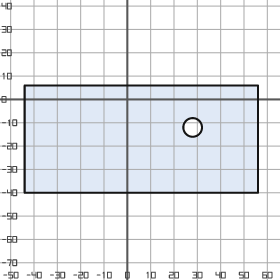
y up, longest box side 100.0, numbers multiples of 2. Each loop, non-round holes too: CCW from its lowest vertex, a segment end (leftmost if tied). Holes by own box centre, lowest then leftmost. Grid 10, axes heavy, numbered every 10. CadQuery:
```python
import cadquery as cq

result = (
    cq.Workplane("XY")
    .moveTo(-44.0, -40.0)
    .lineTo(56.0, -40.0)
    .lineTo(56.0, 6.0)
    .lineTo(-44.0, 6.0)
    .close()
    .moveTo(28.0, -12.0)
    .circle(4.0)
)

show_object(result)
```